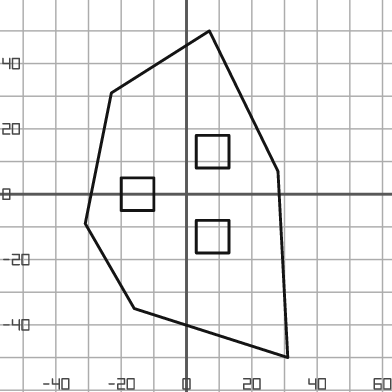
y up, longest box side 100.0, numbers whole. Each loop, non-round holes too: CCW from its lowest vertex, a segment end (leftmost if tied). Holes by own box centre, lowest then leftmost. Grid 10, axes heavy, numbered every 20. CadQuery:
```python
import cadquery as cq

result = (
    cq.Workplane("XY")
    .moveTo(31.0, -50.0)
    .lineTo(28.0, 7.0)
    .lineTo(7.0, 50.0)
    .lineTo(-23.0, 31.0)
    .lineTo(-31.0, -9.0)
    .lineTo(-16.0, -35.0)
    .close()
    .moveTo(3.0, -18.0)
    .lineTo(13.0, -18.0)
    .lineTo(13.0, -8.0)
    .lineTo(3.0, -8.0)
    .close()
    .moveTo(-20.0, -5.0)
    .lineTo(-10.0, -5.0)
    .lineTo(-10.0, 5.0)
    .lineTo(-20.0, 5.0)
    .close()
    .moveTo(3.0, 8.0)
    .lineTo(13.0, 8.0)
    .lineTo(13.0, 18.0)
    .lineTo(3.0, 18.0)
    .close()
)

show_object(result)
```